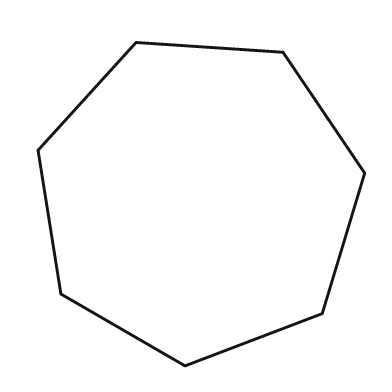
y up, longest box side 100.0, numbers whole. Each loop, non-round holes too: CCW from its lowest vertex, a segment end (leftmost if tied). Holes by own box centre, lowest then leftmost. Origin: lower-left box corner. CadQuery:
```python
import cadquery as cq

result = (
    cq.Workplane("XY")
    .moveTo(45.0, 0.0)
    .lineTo(87.0, 16.0)
    .lineTo(100.0, 59.0)
    .lineTo(75.0, 96.0)
    .lineTo(30.0, 99.0)
    .lineTo(0.0, 66.0)
    .lineTo(7.0, 22.0)
    .close()
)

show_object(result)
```